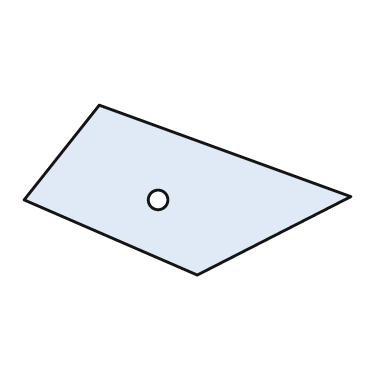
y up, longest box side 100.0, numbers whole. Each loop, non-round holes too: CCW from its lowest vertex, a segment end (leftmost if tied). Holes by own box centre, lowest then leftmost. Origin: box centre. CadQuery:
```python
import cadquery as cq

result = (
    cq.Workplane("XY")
    .moveTo(3.0, -26.0)
    .lineTo(50.0, -2.0)
    .lineTo(-27.0, 26.0)
    .lineTo(-50.0, -3.0)
    .close()
    .moveTo(-9.0, -3.0)
    .circle(3.0)
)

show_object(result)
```